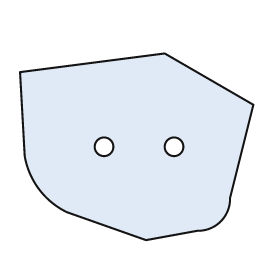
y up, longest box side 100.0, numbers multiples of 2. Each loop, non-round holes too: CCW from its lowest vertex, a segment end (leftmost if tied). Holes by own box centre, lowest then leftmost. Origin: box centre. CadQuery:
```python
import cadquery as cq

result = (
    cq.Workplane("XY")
    .moveTo(4.0, -40.0)
    .lineTo(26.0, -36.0)
    .threePointArc((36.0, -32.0), (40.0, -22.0))
    .lineTo(50.0, 18.0)
    .lineTo(12.0, 40.0)
    .lineTo(-50.0, 32.0)
    .lineTo(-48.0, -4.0)
    .threePointArc((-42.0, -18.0), (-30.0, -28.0))
    .close()
    .moveTo(-14.0, 0.0)
    .circle(4.0)
    .moveTo(16.0, 0.0)
    .circle(4.0)
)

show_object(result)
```